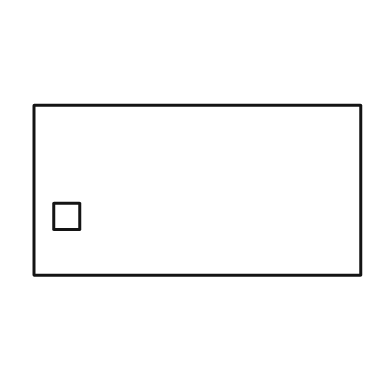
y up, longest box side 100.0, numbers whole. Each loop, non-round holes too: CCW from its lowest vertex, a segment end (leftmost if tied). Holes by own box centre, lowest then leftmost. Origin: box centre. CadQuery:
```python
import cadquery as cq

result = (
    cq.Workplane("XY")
    .moveTo(-50.0, -26.0)
    .lineTo(50.0, -26.0)
    .lineTo(50.0, 26.0)
    .lineTo(-50.0, 26.0)
    .close()
    .moveTo(-44.0, -12.0)
    .lineTo(-36.0, -12.0)
    .lineTo(-36.0, -4.0)
    .lineTo(-44.0, -4.0)
    .close()
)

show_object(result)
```